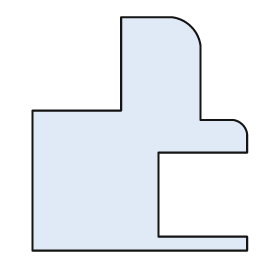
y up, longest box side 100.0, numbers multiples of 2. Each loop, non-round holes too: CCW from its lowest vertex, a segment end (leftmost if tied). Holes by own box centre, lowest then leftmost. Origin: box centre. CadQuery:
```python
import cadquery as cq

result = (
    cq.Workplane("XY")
    .moveTo(-46.0, -50.0)
    .lineTo(46.0, -50.0)
    .lineTo(46.0, -44.0)
    .lineTo(8.0, -44.0)
    .lineTo(8.0, -8.0)
    .lineTo(46.0, -8.0)
    .lineTo(46.0, 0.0)
    .threePointArc((44.0, 4.0), (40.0, 6.0))
    .lineTo(26.0, 6.0)
    .lineTo(26.0, 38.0)
    .threePointArc((22.0, 46.0), (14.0, 50.0))
    .lineTo(-8.0, 50.0)
    .lineTo(-8.0, 10.0)
    .lineTo(-46.0, 10.0)
    .close()
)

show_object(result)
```